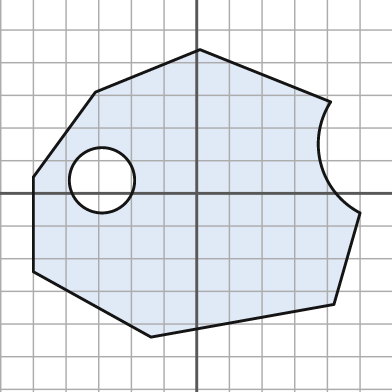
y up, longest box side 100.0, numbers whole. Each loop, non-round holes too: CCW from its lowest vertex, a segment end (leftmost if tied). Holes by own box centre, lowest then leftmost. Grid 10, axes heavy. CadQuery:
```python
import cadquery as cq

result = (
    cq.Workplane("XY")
    .moveTo(-14.0, -44.0)
    .lineTo(42.0, -34.0)
    .lineTo(50.0, -6.0)
    .threePointArc((38.0, 9.0), (41.0, 28.0))
    .lineTo(1.0, 44.0)
    .lineTo(-31.0, 31.0)
    .lineTo(-50.0, 5.0)
    .lineTo(-50.0, -24.0)
    .close()
    .moveTo(-29.0, 4.0)
    .circle(10.0)
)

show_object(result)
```